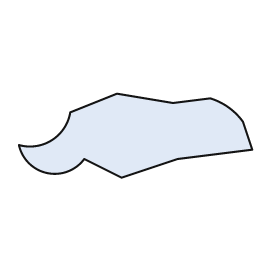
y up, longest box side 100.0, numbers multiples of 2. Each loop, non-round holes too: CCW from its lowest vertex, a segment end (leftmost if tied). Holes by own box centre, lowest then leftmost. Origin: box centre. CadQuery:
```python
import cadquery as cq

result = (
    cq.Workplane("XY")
    .moveTo(-6.0, -18.0)
    .lineTo(18.0, -10.0)
    .lineTo(50.0, -6.0)
    .lineTo(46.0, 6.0)
    .threePointArc((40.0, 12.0), (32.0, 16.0))
    .lineTo(16.0, 14.0)
    .lineTo(-8.0, 18.0)
    .lineTo(-28.0, 10.0)
    .threePointArc((-36.0, -2.0), (-50.0, -4.0))
    .threePointArc((-38.0, -16.0), (-22.0, -10.0))
    .close()
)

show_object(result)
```